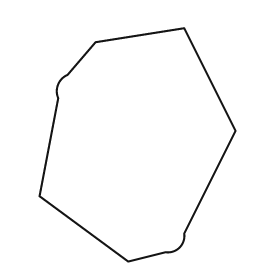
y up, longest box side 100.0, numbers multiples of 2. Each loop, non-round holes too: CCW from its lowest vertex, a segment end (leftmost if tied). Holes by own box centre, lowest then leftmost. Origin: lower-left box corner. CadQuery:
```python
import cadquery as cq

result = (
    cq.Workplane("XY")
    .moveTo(38.0, 0.0)
    .lineTo(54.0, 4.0)
    .threePointArc((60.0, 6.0), (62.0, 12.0))
    .lineTo(84.0, 56.0)
    .lineTo(62.0, 100.0)
    .lineTo(24.0, 94.0)
    .lineTo(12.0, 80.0)
    .threePointArc((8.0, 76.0), (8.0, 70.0))
    .lineTo(0.0, 28.0)
    .close()
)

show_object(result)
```